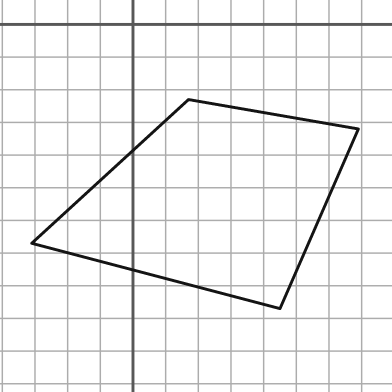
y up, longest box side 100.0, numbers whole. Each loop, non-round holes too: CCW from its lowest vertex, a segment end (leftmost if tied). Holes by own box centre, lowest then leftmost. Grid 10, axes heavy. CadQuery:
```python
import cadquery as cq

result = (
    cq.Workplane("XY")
    .moveTo(45.0, -87.0)
    .lineTo(69.0, -32.0)
    .lineTo(17.0, -23.0)
    .lineTo(-31.0, -67.0)
    .close()
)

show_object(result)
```